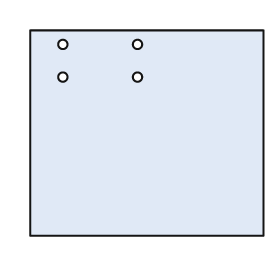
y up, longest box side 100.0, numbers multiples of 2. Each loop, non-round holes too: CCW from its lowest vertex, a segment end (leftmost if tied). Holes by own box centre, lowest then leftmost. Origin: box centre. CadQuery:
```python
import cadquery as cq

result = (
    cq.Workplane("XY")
    .moveTo(-50.0, -44.0)
    .lineTo(50.0, -44.0)
    .lineTo(50.0, 44.0)
    .lineTo(-50.0, 44.0)
    .close()
    .moveTo(-36.0, 24.0)
    .circle(2.0)
    .moveTo(-4.0, 24.0)
    .circle(2.0)
    .moveTo(-36.0, 38.0)
    .circle(2.0)
    .moveTo(-4.0, 38.0)
    .circle(2.0)
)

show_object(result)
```